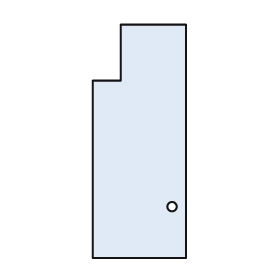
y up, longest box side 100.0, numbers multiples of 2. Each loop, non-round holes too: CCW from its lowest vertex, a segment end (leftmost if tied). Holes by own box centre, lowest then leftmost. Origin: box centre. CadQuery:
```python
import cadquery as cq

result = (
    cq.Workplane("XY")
    .moveTo(-20.0, -50.0)
    .lineTo(20.0, -50.0)
    .lineTo(20.0, 50.0)
    .lineTo(-8.0, 50.0)
    .lineTo(-8.0, 26.0)
    .lineTo(-20.0, 26.0)
    .close()
    .moveTo(14.0, -28.0)
    .circle(2.0)
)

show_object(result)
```